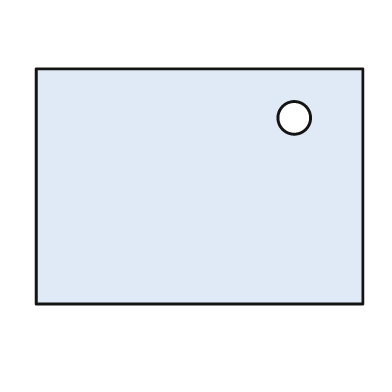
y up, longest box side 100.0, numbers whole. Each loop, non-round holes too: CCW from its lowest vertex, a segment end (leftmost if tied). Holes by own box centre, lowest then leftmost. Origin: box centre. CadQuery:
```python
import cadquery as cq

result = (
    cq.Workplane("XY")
    .moveTo(-50.0, -36.0)
    .lineTo(50.0, -36.0)
    .lineTo(50.0, 36.0)
    .lineTo(-50.0, 36.0)
    .close()
    .moveTo(29.0, 21.0)
    .circle(5.0)
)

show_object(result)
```